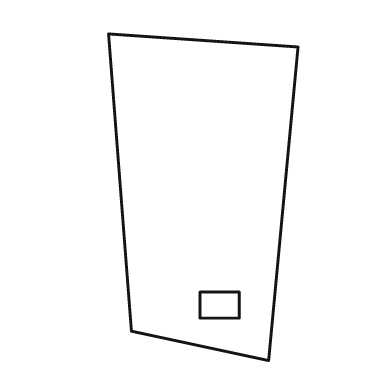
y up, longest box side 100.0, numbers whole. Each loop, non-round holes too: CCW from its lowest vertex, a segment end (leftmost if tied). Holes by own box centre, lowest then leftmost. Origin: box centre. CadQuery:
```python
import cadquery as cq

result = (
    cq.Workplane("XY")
    .moveTo(20.0, -50.0)
    .lineTo(29.0, 46.0)
    .lineTo(-29.0, 50.0)
    .lineTo(-22.0, -41.0)
    .close()
    .moveTo(-1.0, -37.0)
    .lineTo(11.0, -37.0)
    .lineTo(11.0, -29.0)
    .lineTo(-1.0, -29.0)
    .close()
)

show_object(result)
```